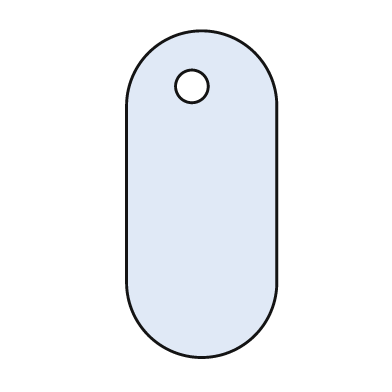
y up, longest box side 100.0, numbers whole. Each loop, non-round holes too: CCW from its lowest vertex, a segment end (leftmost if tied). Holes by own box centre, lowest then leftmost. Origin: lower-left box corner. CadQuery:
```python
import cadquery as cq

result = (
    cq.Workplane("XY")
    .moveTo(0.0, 23.0)
    .threePointArc((23.0, 0.0), (46.0, 23.0))
    .lineTo(46.0, 77.0)
    .threePointArc((23.0, 100.0), (0.0, 77.0))
    .close()
    .moveTo(20.0, 83.0)
    .circle(5.0)
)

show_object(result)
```